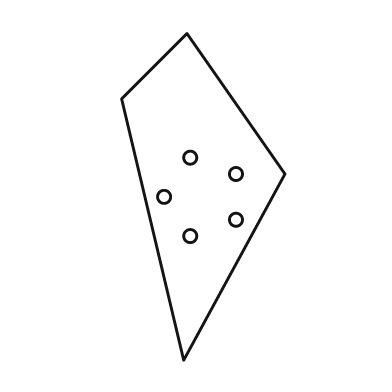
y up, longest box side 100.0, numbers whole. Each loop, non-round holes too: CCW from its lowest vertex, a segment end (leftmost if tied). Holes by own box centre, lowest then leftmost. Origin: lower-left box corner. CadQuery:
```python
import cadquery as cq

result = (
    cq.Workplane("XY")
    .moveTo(19.0, 0.0)
    .lineTo(50.0, 57.0)
    .lineTo(20.0, 100.0)
    .lineTo(0.0, 80.0)
    .close()
    .moveTo(21.0, 38.0)
    .circle(2.0)
    .moveTo(35.0, 43.0)
    .circle(2.0)
    .moveTo(13.0, 50.0)
    .circle(2.0)
    .moveTo(35.0, 57.0)
    .circle(2.0)
    .moveTo(21.0, 62.0)
    .circle(2.0)
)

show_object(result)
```